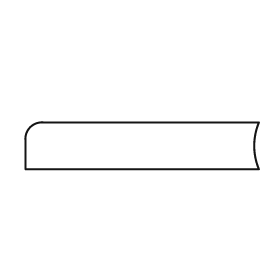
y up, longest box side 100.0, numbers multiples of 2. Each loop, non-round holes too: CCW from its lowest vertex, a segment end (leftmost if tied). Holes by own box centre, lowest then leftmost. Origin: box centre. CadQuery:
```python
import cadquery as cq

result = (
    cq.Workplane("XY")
    .moveTo(-50.0, -10.0)
    .lineTo(50.0, -10.0)
    .threePointArc((48.0, 0.0), (50.0, 10.0))
    .lineTo(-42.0, 10.0)
    .threePointArc((-48.0, 8.0), (-50.0, 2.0))
    .close()
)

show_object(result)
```